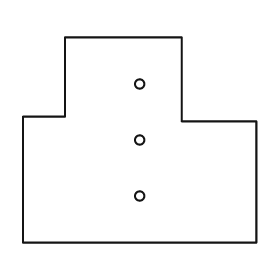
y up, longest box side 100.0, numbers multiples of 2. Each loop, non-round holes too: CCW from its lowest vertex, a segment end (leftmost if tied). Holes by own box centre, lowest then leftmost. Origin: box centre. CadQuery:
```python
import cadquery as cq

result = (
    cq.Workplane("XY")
    .moveTo(-50.0, -44.0)
    .lineTo(50.0, -44.0)
    .lineTo(50.0, 8.0)
    .lineTo(18.0, 8.0)
    .lineTo(18.0, 44.0)
    .lineTo(-32.0, 44.0)
    .lineTo(-32.0, 10.0)
    .lineTo(-50.0, 10.0)
    .close()
    .moveTo(0.0, -24.0)
    .circle(2.0)
    .moveTo(0.0, 0.0)
    .circle(2.0)
    .moveTo(0.0, 24.0)
    .circle(2.0)
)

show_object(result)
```